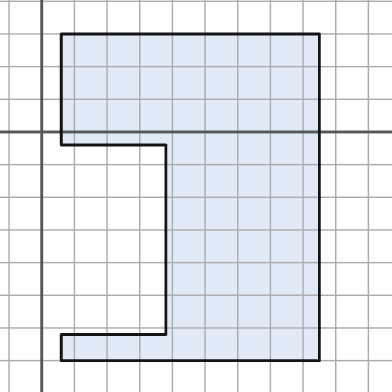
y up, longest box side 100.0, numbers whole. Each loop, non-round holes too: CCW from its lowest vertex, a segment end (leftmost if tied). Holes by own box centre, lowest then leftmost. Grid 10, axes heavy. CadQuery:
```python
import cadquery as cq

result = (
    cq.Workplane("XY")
    .moveTo(6.0, -70.0)
    .lineTo(85.0, -70.0)
    .lineTo(85.0, 30.0)
    .lineTo(6.0, 30.0)
    .lineTo(6.0, -4.0)
    .lineTo(38.0, -4.0)
    .lineTo(38.0, -62.0)
    .lineTo(6.0, -62.0)
    .close()
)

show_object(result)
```